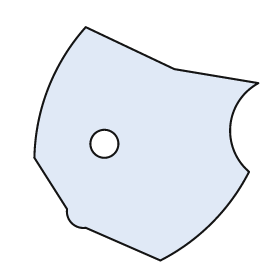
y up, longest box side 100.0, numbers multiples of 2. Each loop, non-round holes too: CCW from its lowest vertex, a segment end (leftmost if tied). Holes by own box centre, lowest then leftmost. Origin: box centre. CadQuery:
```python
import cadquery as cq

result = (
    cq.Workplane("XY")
    .moveTo(6.0, -50.0)
    .threePointArc((28.0, -34.0), (44.0, -12.0))
    .threePointArc((36.0, 8.0), (48.0, 26.0))
    .lineTo(12.0, 32.0)
    .lineTo(-26.0, 50.0)
    .threePointArc((-42.0, 24.0), (-48.0, -6.0))
    .lineTo(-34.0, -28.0)
    .threePointArc((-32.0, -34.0), (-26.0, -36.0))
    .close()
    .moveTo(-18.0, 0.0)
    .circle(6.0)
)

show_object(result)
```